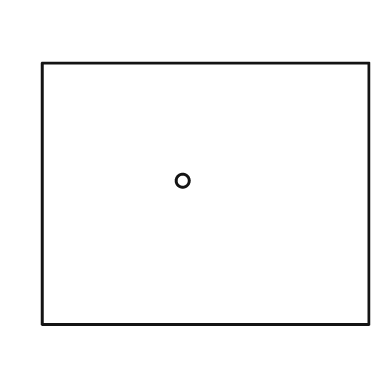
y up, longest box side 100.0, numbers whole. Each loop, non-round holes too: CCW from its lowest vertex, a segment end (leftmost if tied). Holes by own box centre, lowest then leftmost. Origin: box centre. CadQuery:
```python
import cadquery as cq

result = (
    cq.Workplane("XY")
    .moveTo(-50.0, -40.0)
    .lineTo(50.0, -40.0)
    .lineTo(50.0, 40.0)
    .lineTo(-50.0, 40.0)
    .close()
    .moveTo(-7.0, 4.0)
    .circle(2.0)
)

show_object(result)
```